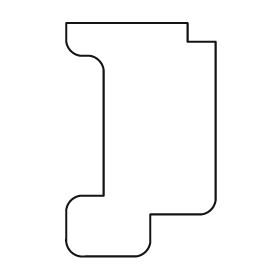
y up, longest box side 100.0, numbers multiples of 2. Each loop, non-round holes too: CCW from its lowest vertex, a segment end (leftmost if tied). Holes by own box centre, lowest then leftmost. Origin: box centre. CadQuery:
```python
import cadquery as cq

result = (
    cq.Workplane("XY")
    .moveTo(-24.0, -50.0)
    .lineTo(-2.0, -50.0)
    .threePointArc((2.0, -48.0), (4.0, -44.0))
    .lineTo(4.0, -32.0)
    .lineTo(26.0, -32.0)
    .threePointArc((30.0, -30.0), (32.0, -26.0))
    .lineTo(32.0, 42.0)
    .lineTo(20.0, 42.0)
    .lineTo(20.0, 50.0)
    .lineTo(-32.0, 50.0)
    .lineTo(-32.0, 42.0)
    .threePointArc((-30.0, 38.0), (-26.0, 36.0))
    .lineTo(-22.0, 36.0)
    .threePointArc((-18.0, 34.0), (-16.0, 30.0))
    .lineTo(-16.0, -24.0)
    .lineTo(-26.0, -24.0)
    .threePointArc((-30.0, -26.0), (-32.0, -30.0))
    .lineTo(-32.0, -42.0)
    .threePointArc((-30.0, -48.0), (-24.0, -50.0))
    .close()
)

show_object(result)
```